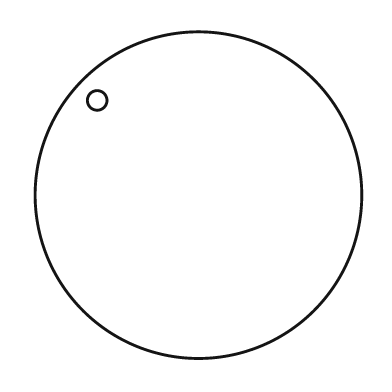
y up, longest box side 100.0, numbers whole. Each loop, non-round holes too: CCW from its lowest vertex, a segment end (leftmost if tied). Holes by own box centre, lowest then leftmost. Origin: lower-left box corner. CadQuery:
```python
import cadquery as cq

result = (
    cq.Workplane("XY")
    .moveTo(50.0, 50.0)
    .circle(50.0)
    .moveTo(19.0, 79.0)
    .circle(3.0)
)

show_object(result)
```